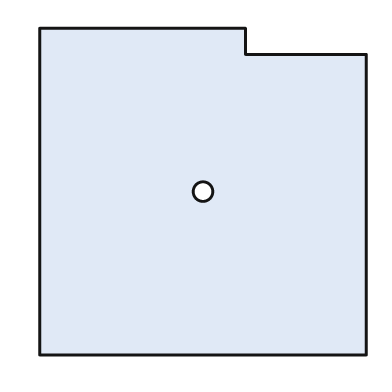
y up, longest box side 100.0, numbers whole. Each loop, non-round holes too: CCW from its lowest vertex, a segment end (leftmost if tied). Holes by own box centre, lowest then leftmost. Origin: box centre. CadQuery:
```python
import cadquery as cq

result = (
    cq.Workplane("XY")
    .moveTo(-50.0, -50.0)
    .lineTo(50.0, -50.0)
    .lineTo(50.0, 42.0)
    .lineTo(13.0, 42.0)
    .lineTo(13.0, 50.0)
    .lineTo(-50.0, 50.0)
    .close()
    .moveTo(0.0, 0.0)
    .circle(3.0)
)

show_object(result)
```